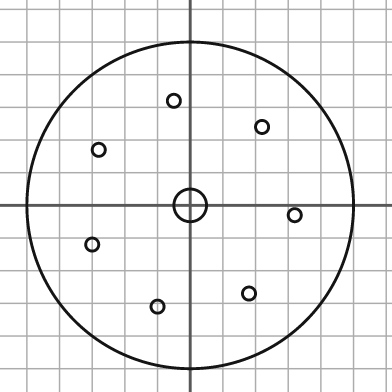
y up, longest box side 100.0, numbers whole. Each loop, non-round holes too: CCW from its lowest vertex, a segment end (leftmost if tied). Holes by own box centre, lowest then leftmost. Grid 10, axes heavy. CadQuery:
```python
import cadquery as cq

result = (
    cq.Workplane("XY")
    .moveTo(0.0, 0.0)
    .circle(50.0)
    .moveTo(-10.0, -31.0)
    .circle(2.0)
    .moveTo(18.0, -27.0)
    .circle(2.0)
    .moveTo(-30.0, -12.0)
    .circle(2.0)
    .moveTo(32.0, -3.0)
    .circle(2.0)
    .moveTo(0.0, 0.0)
    .circle(5.0)
    .moveTo(-28.0, 17.0)
    .circle(2.0)
    .moveTo(22.0, 24.0)
    .circle(2.0)
    .moveTo(-5.0, 32.0)
    .circle(2.0)
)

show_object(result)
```